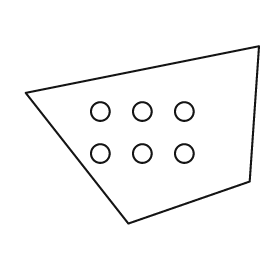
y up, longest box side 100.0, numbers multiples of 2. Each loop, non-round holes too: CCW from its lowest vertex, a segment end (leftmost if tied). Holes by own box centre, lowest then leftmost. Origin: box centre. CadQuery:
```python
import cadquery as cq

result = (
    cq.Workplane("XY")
    .moveTo(-6.0, -38.0)
    .lineTo(46.0, -20.0)
    .lineTo(50.0, 38.0)
    .lineTo(-50.0, 18.0)
    .close()
    .moveTo(-18.0, -8.0)
    .circle(4.0)
    .moveTo(0.0, -8.0)
    .circle(4.0)
    .moveTo(18.0, -8.0)
    .circle(4.0)
    .moveTo(-18.0, 10.0)
    .circle(4.0)
    .moveTo(0.0, 10.0)
    .circle(4.0)
    .moveTo(18.0, 10.0)
    .circle(4.0)
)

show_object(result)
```